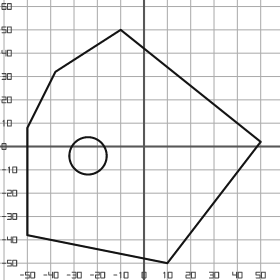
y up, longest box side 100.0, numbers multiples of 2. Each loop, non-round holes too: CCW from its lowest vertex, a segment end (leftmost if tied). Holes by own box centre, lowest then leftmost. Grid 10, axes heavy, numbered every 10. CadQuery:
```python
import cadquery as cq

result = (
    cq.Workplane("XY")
    .moveTo(10.0, -50.0)
    .lineTo(50.0, 2.0)
    .lineTo(-10.0, 50.0)
    .lineTo(-38.0, 32.0)
    .lineTo(-50.0, 8.0)
    .lineTo(-50.0, -38.0)
    .close()
    .moveTo(-24.0, -4.0)
    .circle(8.0)
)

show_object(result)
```